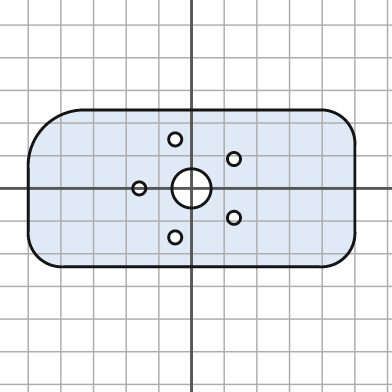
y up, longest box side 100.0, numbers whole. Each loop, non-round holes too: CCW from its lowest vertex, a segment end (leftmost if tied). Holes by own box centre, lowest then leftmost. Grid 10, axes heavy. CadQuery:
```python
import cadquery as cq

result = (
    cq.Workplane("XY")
    .moveTo(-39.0, -24.0)
    .lineTo(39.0, -24.0)
    .threePointArc((47.0, -21.0), (50.0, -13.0))
    .lineTo(50.0, 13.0)
    .threePointArc((47.0, 21.0), (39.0, 24.0))
    .lineTo(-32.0, 24.0)
    .threePointArc((-45.0, 19.0), (-50.0, 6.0))
    .lineTo(-50.0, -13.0)
    .threePointArc((-47.0, -21.0), (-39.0, -24.0))
    .close()
    .moveTo(-5.0, -15.0)
    .circle(2.0)
    .moveTo(13.0, -9.0)
    .circle(2.0)
    .moveTo(-16.0, 0.0)
    .circle(2.0)
    .moveTo(0.0, 0.0)
    .circle(6.0)
    .moveTo(13.0, 9.0)
    .circle(2.0)
    .moveTo(-5.0, 15.0)
    .circle(2.0)
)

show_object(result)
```